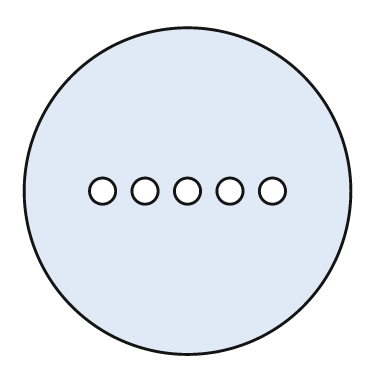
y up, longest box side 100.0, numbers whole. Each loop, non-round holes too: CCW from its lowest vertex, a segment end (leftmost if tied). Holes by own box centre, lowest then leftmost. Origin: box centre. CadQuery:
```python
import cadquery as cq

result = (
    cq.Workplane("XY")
    .moveTo(0.0, 0.0)
    .circle(50.0)
    .moveTo(-26.0, 0.0)
    .circle(4.0)
    .moveTo(-13.0, 0.0)
    .circle(4.0)
    .moveTo(0.0, 0.0)
    .circle(4.0)
    .moveTo(13.0, 0.0)
    .circle(4.0)
    .moveTo(26.0, 0.0)
    .circle(4.0)
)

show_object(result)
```